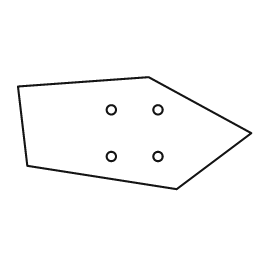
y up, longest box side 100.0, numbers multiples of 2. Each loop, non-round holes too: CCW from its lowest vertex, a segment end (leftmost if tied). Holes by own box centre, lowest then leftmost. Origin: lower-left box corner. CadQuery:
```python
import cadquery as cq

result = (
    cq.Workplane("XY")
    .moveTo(68.0, 0.0)
    .lineTo(100.0, 24.0)
    .lineTo(56.0, 48.0)
    .lineTo(0.0, 44.0)
    .lineTo(4.0, 10.0)
    .close()
    .moveTo(40.0, 14.0)
    .circle(2.0)
    .moveTo(60.0, 14.0)
    .circle(2.0)
    .moveTo(40.0, 34.0)
    .circle(2.0)
    .moveTo(60.0, 34.0)
    .circle(2.0)
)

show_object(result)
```